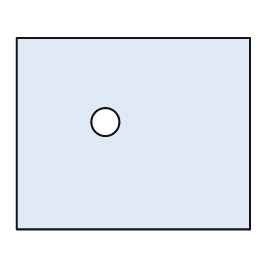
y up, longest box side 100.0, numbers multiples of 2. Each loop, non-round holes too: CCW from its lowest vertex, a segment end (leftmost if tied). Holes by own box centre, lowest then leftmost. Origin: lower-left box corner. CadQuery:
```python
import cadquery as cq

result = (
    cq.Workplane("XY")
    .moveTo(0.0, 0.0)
    .lineTo(100.0, 0.0)
    .lineTo(100.0, 82.0)
    .lineTo(0.0, 82.0)
    .close()
    .moveTo(38.0, 46.0)
    .circle(6.0)
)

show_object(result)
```